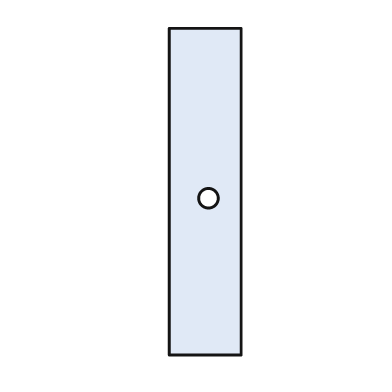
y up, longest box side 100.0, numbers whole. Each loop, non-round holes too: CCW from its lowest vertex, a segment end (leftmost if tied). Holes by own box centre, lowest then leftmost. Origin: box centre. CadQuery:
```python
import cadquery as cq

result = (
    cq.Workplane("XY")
    .moveTo(-11.0, -50.0)
    .lineTo(11.0, -50.0)
    .lineTo(11.0, 50.0)
    .lineTo(-11.0, 50.0)
    .close()
    .moveTo(1.0, -2.0)
    .circle(3.0)
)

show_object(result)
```